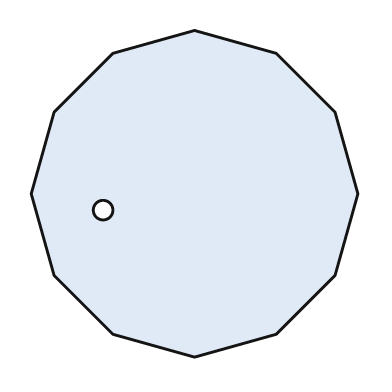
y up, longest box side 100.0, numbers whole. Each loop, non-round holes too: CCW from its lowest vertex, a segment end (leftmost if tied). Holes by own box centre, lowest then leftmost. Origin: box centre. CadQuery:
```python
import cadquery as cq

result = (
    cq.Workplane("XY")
    .moveTo(0.0, -50.0)
    .lineTo(25.0, -43.0)
    .lineTo(43.0, -25.0)
    .lineTo(50.0, 0.0)
    .lineTo(43.0, 25.0)
    .lineTo(25.0, 43.0)
    .lineTo(0.0, 50.0)
    .lineTo(-25.0, 43.0)
    .lineTo(-43.0, 25.0)
    .lineTo(-50.0, 0.0)
    .lineTo(-43.0, -25.0)
    .lineTo(-25.0, -43.0)
    .close()
    .moveTo(-28.0, -5.0)
    .circle(3.0)
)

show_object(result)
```